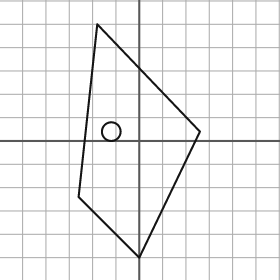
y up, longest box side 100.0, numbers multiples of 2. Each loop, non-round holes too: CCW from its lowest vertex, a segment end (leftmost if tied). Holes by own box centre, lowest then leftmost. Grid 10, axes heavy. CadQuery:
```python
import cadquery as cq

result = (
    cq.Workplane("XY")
    .moveTo(0.0, -50.0)
    .lineTo(26.0, 4.0)
    .lineTo(-18.0, 50.0)
    .lineTo(-26.0, -24.0)
    .close()
    .moveTo(-12.0, 4.0)
    .circle(4.0)
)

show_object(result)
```